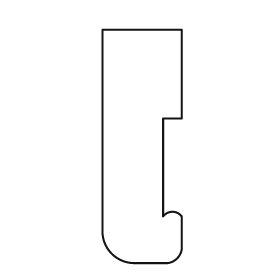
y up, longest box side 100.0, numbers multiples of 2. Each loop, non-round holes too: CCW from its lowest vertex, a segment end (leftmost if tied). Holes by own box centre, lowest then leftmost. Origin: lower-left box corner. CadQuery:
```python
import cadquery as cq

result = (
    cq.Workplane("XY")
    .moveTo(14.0, 0.0)
    .lineTo(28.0, 0.0)
    .threePointArc((32.0, 2.0), (34.0, 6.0))
    .lineTo(34.0, 20.0)
    .threePointArc((30.0, 22.0), (26.0, 20.0))
    .lineTo(26.0, 62.0)
    .lineTo(34.0, 62.0)
    .lineTo(34.0, 100.0)
    .lineTo(0.0, 100.0)
    .lineTo(0.0, 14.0)
    .threePointArc((4.0, 4.0), (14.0, 0.0))
    .close()
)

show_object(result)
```